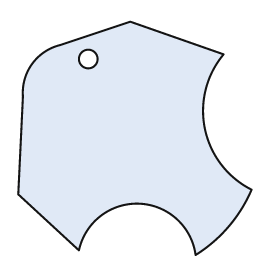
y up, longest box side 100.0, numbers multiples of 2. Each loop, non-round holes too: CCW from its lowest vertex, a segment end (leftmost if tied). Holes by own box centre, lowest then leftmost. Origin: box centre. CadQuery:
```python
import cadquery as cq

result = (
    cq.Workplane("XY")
    .moveTo(26.0, -50.0)
    .threePointArc((40.0, -38.0), (50.0, -22.0))
    .threePointArc((30.0, 4.0), (38.0, 36.0))
    .lineTo(-2.0, 50.0)
    .lineTo(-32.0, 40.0)
    .threePointArc((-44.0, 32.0), (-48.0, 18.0))
    .lineTo(-50.0, -24.0)
    .lineTo(-24.0, -48.0)
    .threePointArc((2.0, -28.0), (26.0, -50.0))
    .close()
    .moveTo(-20.0, 34.0)
    .circle(4.0)
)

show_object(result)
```